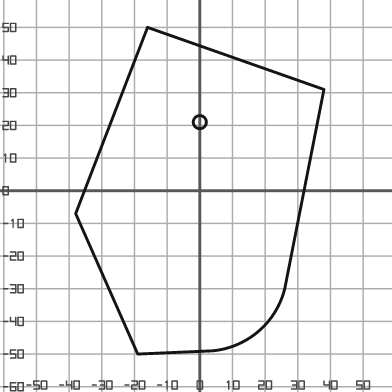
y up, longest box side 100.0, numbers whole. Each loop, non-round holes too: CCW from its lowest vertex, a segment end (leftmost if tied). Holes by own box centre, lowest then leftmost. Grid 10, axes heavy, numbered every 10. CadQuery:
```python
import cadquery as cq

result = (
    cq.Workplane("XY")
    .moveTo(-19.0, -50.0)
    .lineTo(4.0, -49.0)
    .threePointArc((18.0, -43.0), (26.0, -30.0))
    .lineTo(38.0, 31.0)
    .lineTo(-16.0, 50.0)
    .lineTo(-38.0, -7.0)
    .close()
    .moveTo(0.0, 21.0)
    .circle(2.0)
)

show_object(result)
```